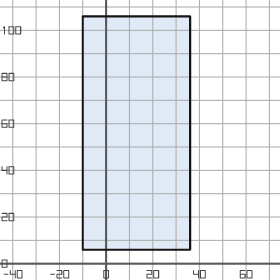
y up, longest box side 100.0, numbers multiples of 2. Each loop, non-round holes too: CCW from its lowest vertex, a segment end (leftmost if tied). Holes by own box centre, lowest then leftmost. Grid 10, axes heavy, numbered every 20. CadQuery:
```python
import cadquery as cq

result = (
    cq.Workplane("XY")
    .moveTo(-10.0, 6.0)
    .lineTo(36.0, 6.0)
    .lineTo(36.0, 106.0)
    .lineTo(-10.0, 106.0)
    .close()
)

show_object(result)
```